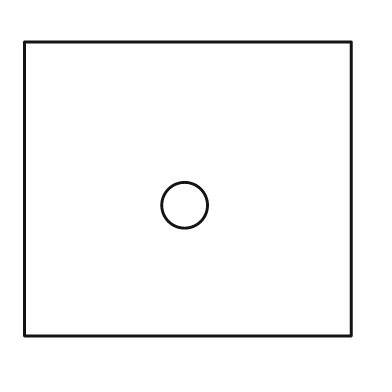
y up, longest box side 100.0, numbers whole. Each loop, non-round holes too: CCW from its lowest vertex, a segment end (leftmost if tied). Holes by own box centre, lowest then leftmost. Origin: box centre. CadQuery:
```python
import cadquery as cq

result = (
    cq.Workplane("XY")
    .moveTo(-50.0, -45.0)
    .lineTo(50.0, -45.0)
    .lineTo(50.0, 45.0)
    .lineTo(-50.0, 45.0)
    .close()
    .moveTo(-1.0, -5.0)
    .circle(7.0)
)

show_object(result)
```